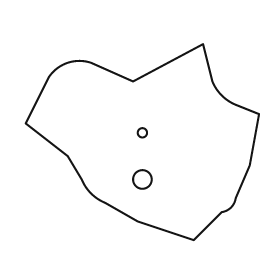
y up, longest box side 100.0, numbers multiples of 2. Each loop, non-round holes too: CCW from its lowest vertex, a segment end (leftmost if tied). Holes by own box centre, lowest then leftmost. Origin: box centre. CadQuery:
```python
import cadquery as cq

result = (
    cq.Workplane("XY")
    .moveTo(22.0, -42.0)
    .lineTo(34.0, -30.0)
    .threePointArc((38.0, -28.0), (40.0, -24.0))
    .lineTo(46.0, -10.0)
    .lineTo(50.0, 12.0)
    .lineTo(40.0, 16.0)
    .threePointArc((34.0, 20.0), (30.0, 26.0))
    .lineTo(26.0, 42.0)
    .lineTo(-4.0, 26.0)
    .lineTo(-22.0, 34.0)
    .threePointArc((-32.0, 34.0), (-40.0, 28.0))
    .lineTo(-50.0, 8.0)
    .lineTo(-32.0, -6.0)
    .lineTo(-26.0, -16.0)
    .threePointArc((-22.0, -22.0), (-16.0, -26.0))
    .lineTo(-2.0, -34.0)
    .close()
    .moveTo(0.0, -16.0)
    .circle(4.0)
    .moveTo(0.0, 4.0)
    .circle(2.0)
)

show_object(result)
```